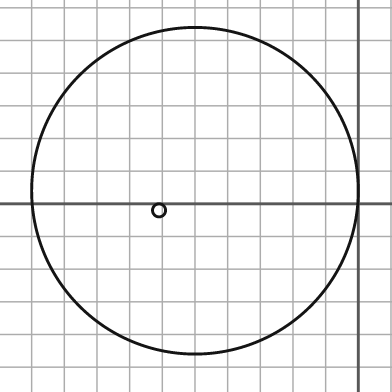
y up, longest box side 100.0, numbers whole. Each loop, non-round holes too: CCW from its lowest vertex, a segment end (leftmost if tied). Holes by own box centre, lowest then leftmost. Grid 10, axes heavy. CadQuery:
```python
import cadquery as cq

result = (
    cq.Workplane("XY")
    .moveTo(-50.0, 4.0)
    .circle(50.0)
    .moveTo(-61.0, -2.0)
    .circle(2.0)
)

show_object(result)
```